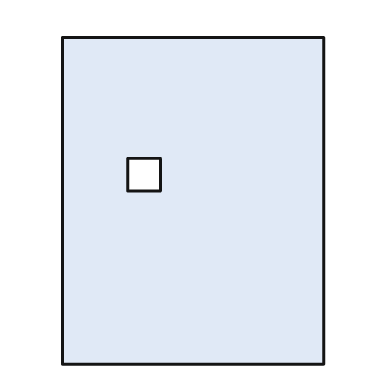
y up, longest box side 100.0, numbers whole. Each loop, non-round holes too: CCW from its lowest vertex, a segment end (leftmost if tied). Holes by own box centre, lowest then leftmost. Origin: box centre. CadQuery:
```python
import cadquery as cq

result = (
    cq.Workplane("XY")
    .moveTo(-40.0, -50.0)
    .lineTo(40.0, -50.0)
    .lineTo(40.0, 50.0)
    .lineTo(-40.0, 50.0)
    .close()
    .moveTo(-20.0, 3.0)
    .lineTo(-10.0, 3.0)
    .lineTo(-10.0, 13.0)
    .lineTo(-20.0, 13.0)
    .close()
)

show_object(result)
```